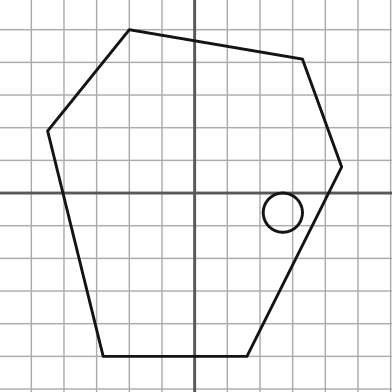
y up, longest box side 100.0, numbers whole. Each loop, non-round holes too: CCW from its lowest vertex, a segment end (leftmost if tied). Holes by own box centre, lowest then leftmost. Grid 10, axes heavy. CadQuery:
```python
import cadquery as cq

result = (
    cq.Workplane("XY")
    .moveTo(-28.0, -50.0)
    .lineTo(16.0, -50.0)
    .lineTo(45.0, 8.0)
    .lineTo(33.0, 41.0)
    .lineTo(-20.0, 50.0)
    .lineTo(-45.0, 19.0)
    .close()
    .moveTo(27.0, -6.0)
    .circle(6.0)
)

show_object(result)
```